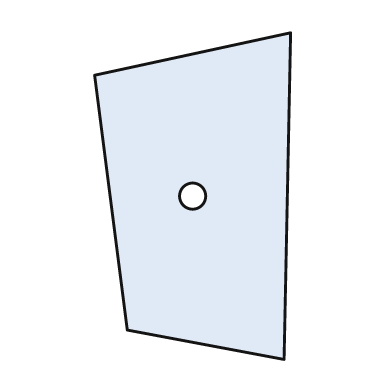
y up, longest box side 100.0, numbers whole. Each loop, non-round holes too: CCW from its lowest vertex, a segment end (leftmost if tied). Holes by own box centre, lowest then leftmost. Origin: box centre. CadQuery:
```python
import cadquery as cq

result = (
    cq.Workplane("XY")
    .moveTo(28.0, -50.0)
    .lineTo(30.0, 50.0)
    .lineTo(-30.0, 37.0)
    .lineTo(-20.0, -41.0)
    .close()
    .moveTo(0.0, 0.0)
    .circle(4.0)
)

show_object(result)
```